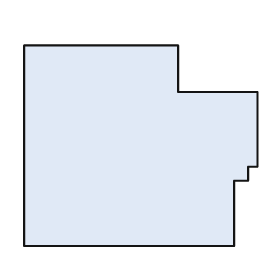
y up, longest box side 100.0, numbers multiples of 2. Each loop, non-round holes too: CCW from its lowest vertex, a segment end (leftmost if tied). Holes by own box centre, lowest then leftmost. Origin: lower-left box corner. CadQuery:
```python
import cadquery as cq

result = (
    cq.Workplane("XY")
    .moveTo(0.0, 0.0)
    .lineTo(90.0, 0.0)
    .lineTo(90.0, 28.0)
    .lineTo(96.0, 28.0)
    .lineTo(96.0, 34.0)
    .lineTo(100.0, 34.0)
    .lineTo(100.0, 66.0)
    .lineTo(66.0, 66.0)
    .lineTo(66.0, 86.0)
    .lineTo(0.0, 86.0)
    .close()
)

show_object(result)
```